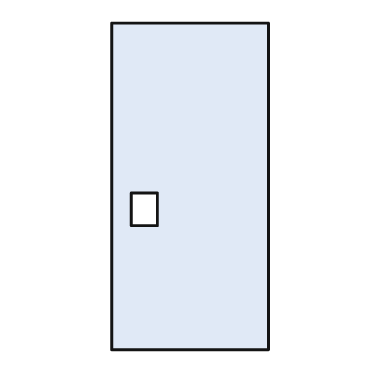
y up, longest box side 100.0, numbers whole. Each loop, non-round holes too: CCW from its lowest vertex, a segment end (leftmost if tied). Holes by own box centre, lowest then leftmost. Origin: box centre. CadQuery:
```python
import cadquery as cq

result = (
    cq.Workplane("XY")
    .moveTo(-24.0, -50.0)
    .lineTo(24.0, -50.0)
    .lineTo(24.0, 50.0)
    .lineTo(-24.0, 50.0)
    .close()
    .moveTo(-18.0, -12.0)
    .lineTo(-10.0, -12.0)
    .lineTo(-10.0, -2.0)
    .lineTo(-18.0, -2.0)
    .close()
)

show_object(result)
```